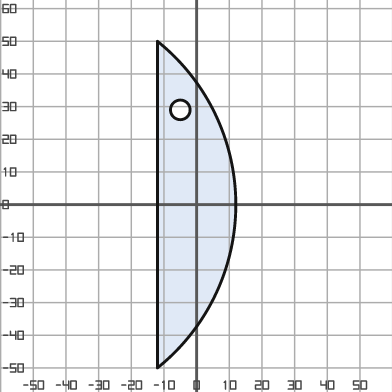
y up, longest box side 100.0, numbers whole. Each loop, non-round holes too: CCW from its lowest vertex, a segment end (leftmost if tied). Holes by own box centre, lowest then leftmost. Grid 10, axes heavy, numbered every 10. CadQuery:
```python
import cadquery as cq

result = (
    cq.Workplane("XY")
    .moveTo(-12.0, -50.0)
    .threePointArc((12.0, 0.0), (-12.0, 50.0))
    .close()
    .moveTo(-5.0, 29.0)
    .circle(3.0)
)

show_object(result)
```